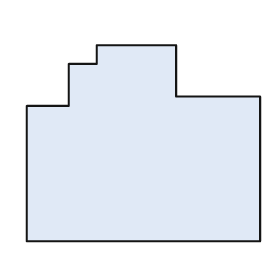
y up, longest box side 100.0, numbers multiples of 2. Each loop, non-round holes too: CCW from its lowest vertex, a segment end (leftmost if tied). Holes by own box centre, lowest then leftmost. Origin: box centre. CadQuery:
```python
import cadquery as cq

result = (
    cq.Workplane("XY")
    .moveTo(-50.0, -42.0)
    .lineTo(50.0, -42.0)
    .lineTo(50.0, 20.0)
    .lineTo(14.0, 20.0)
    .lineTo(14.0, 42.0)
    .lineTo(-20.0, 42.0)
    .lineTo(-20.0, 34.0)
    .lineTo(-32.0, 34.0)
    .lineTo(-32.0, 16.0)
    .lineTo(-50.0, 16.0)
    .close()
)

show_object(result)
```